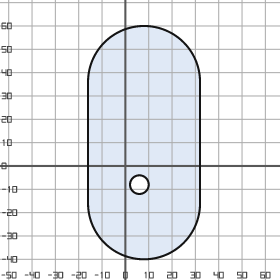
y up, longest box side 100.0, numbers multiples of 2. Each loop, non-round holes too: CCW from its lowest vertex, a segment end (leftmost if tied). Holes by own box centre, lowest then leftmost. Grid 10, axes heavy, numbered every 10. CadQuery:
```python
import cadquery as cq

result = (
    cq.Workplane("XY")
    .moveTo(-16.0, -16.0)
    .threePointArc((8.0, -40.0), (32.0, -16.0))
    .lineTo(32.0, 36.0)
    .threePointArc((8.0, 60.0), (-16.0, 36.0))
    .close()
    .moveTo(6.0, -8.0)
    .circle(4.0)
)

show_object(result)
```